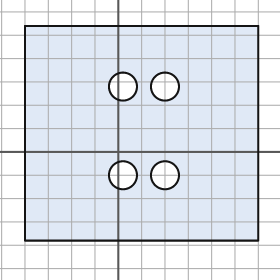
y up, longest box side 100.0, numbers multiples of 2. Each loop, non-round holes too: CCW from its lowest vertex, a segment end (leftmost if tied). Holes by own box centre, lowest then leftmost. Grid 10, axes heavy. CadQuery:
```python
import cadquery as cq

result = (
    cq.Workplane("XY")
    .moveTo(-40.0, -38.0)
    .lineTo(60.0, -38.0)
    .lineTo(60.0, 54.0)
    .lineTo(-40.0, 54.0)
    .close()
    .moveTo(2.0, -10.0)
    .circle(6.0)
    .moveTo(20.0, -10.0)
    .circle(6.0)
    .moveTo(2.0, 28.0)
    .circle(6.0)
    .moveTo(20.0, 28.0)
    .circle(6.0)
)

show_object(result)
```